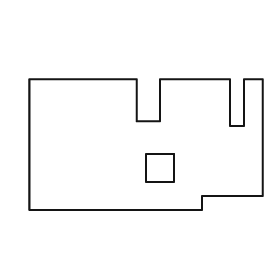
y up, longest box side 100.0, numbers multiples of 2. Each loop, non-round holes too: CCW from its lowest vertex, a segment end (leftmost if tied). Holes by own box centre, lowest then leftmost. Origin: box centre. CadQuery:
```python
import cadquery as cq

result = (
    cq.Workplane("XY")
    .moveTo(-50.0, -28.0)
    .lineTo(24.0, -28.0)
    .lineTo(24.0, -22.0)
    .lineTo(50.0, -22.0)
    .lineTo(50.0, 28.0)
    .lineTo(42.0, 28.0)
    .lineTo(42.0, 8.0)
    .lineTo(36.0, 8.0)
    .lineTo(36.0, 28.0)
    .lineTo(6.0, 28.0)
    .lineTo(6.0, 10.0)
    .lineTo(-4.0, 10.0)
    .lineTo(-4.0, 28.0)
    .lineTo(-50.0, 28.0)
    .close()
    .moveTo(0.0, -16.0)
    .lineTo(12.0, -16.0)
    .lineTo(12.0, -4.0)
    .lineTo(0.0, -4.0)
    .close()
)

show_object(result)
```